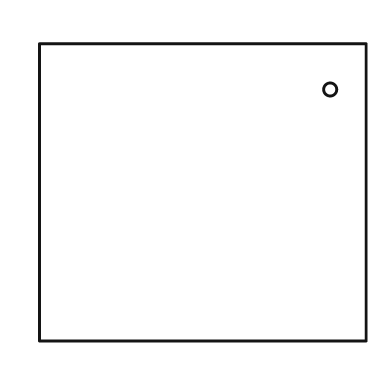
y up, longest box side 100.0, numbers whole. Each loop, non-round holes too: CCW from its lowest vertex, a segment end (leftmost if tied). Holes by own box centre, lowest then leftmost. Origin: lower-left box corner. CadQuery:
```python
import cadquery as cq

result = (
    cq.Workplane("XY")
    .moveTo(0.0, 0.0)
    .lineTo(100.0, 0.0)
    .lineTo(100.0, 91.0)
    .lineTo(0.0, 91.0)
    .close()
    .moveTo(89.0, 77.0)
    .circle(2.0)
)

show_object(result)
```